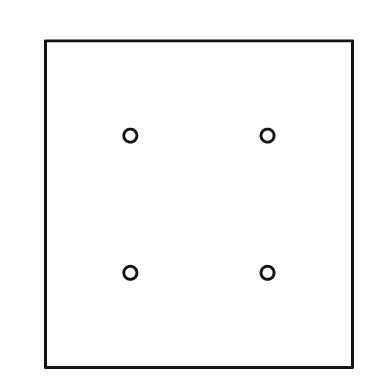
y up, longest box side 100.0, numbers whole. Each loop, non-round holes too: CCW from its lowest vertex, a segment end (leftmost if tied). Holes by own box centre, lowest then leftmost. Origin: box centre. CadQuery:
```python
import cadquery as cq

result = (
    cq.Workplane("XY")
    .moveTo(-47.0, -50.0)
    .lineTo(47.0, -50.0)
    .lineTo(47.0, 50.0)
    .lineTo(-47.0, 50.0)
    .close()
    .moveTo(-21.0, -21.0)
    .circle(2.0)
    .moveTo(21.0, -21.0)
    .circle(2.0)
    .moveTo(-21.0, 21.0)
    .circle(2.0)
    .moveTo(21.0, 21.0)
    .circle(2.0)
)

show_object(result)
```